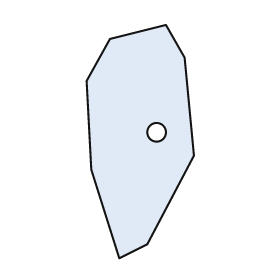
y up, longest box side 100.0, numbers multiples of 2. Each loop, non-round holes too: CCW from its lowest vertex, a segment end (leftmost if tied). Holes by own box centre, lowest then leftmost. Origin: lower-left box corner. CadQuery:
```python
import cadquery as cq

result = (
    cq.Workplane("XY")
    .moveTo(14.0, 0.0)
    .lineTo(26.0, 6.0)
    .lineTo(46.0, 44.0)
    .lineTo(42.0, 86.0)
    .lineTo(34.0, 100.0)
    .lineTo(10.0, 94.0)
    .lineTo(0.0, 76.0)
    .lineTo(2.0, 38.0)
    .close()
    .moveTo(30.0, 54.0)
    .circle(4.0)
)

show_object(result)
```